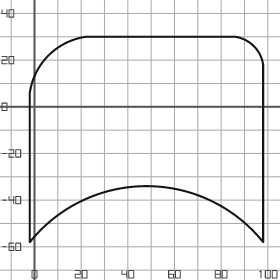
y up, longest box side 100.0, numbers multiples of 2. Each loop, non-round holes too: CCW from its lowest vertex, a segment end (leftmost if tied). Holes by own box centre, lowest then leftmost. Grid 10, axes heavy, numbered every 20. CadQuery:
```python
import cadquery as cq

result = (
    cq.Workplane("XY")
    .moveTo(-2.0, -58.0)
    .threePointArc((48.0, -34.0), (98.0, -58.0))
    .lineTo(98.0, 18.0)
    .threePointArc((94.0, 26.0), (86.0, 30.0))
    .lineTo(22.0, 30.0)
    .threePointArc((6.0, 22.0), (-2.0, 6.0))
    .close()
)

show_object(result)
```